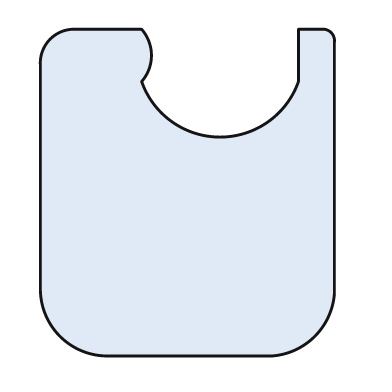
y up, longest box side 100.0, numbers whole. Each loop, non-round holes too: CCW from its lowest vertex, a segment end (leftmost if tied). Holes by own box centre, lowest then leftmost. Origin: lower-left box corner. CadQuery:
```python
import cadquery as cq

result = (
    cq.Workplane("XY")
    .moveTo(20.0, 0.0)
    .lineTo(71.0, 0.0)
    .threePointArc((84.0, 6.0), (90.0, 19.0))
    .lineTo(90.0, 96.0)
    .threePointArc((89.0, 99.0), (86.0, 100.0))
    .lineTo(79.0, 100.0)
    .lineTo(79.0, 84.0)
    .threePointArc((55.0, 67.0), (31.0, 84.0))
    .threePointArc((34.0, 92.0), (31.0, 100.0))
    .lineTo(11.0, 100.0)
    .threePointArc((3.0, 97.0), (0.0, 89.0))
    .lineTo(0.0, 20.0)
    .threePointArc((6.0, 6.0), (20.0, 0.0))
    .close()
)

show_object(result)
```